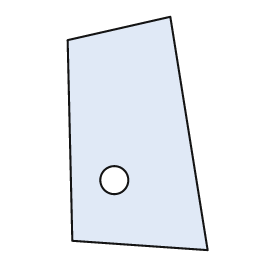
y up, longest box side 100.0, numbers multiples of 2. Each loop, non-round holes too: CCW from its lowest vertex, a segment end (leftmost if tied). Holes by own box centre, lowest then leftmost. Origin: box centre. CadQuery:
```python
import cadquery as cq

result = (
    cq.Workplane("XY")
    .moveTo(30.0, -50.0)
    .lineTo(14.0, 50.0)
    .lineTo(-30.0, 40.0)
    .lineTo(-28.0, -46.0)
    .close()
    .moveTo(-10.0, -20.0)
    .circle(6.0)
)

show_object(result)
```